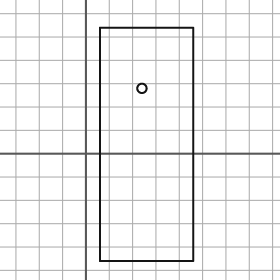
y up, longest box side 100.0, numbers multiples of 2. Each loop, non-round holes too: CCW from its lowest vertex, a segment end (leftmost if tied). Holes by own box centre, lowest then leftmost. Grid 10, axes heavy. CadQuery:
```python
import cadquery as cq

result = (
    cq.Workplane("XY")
    .moveTo(6.0, -46.0)
    .lineTo(46.0, -46.0)
    .lineTo(46.0, 54.0)
    .lineTo(6.0, 54.0)
    .close()
    .moveTo(24.0, 28.0)
    .circle(2.0)
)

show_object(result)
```